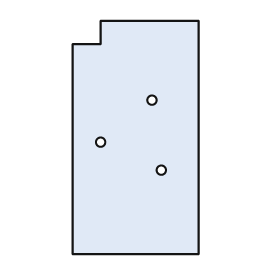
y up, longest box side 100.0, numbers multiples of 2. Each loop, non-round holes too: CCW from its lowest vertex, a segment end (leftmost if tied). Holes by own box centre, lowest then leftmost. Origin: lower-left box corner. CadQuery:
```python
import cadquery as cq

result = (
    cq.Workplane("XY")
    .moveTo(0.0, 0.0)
    .lineTo(54.0, 0.0)
    .lineTo(54.0, 100.0)
    .lineTo(12.0, 100.0)
    .lineTo(12.0, 90.0)
    .lineTo(0.0, 90.0)
    .close()
    .moveTo(38.0, 36.0)
    .circle(2.0)
    .moveTo(12.0, 48.0)
    .circle(2.0)
    .moveTo(34.0, 66.0)
    .circle(2.0)
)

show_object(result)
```